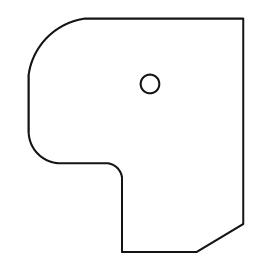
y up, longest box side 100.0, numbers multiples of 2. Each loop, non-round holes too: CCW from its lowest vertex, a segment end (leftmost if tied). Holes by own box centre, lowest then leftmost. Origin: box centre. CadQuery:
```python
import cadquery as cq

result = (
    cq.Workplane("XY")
    .moveTo(-6.0, -50.0)
    .lineTo(26.0, -50.0)
    .lineTo(46.0, -38.0)
    .lineTo(46.0, 50.0)
    .lineTo(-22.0, 50.0)
    .threePointArc((-38.0, 42.0), (-46.0, 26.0))
    .lineTo(-46.0, 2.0)
    .threePointArc((-42.0, -8.0), (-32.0, -12.0))
    .lineTo(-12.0, -12.0)
    .threePointArc((-8.0, -14.0), (-6.0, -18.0))
    .close()
    .moveTo(6.0, 22.0)
    .circle(4.0)
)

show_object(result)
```